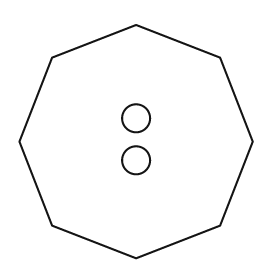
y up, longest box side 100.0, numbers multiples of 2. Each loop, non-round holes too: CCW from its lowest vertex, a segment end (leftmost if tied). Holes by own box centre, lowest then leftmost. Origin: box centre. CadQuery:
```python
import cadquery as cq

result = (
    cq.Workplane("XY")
    .moveTo(0.0, -50.0)
    .lineTo(36.0, -36.0)
    .lineTo(50.0, 0.0)
    .lineTo(36.0, 36.0)
    .lineTo(0.0, 50.0)
    .lineTo(-36.0, 36.0)
    .lineTo(-50.0, 0.0)
    .lineTo(-36.0, -36.0)
    .close()
    .moveTo(0.0, -8.0)
    .circle(6.0)
    .moveTo(0.0, 10.0)
    .circle(6.0)
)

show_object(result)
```